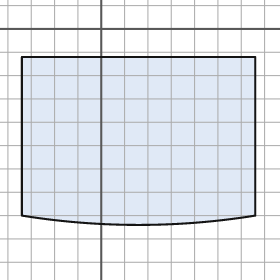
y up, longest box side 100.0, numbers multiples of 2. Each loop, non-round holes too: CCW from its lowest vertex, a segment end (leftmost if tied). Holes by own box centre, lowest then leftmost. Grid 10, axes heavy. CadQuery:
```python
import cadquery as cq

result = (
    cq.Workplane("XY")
    .moveTo(-34.0, -80.0)
    .threePointArc((16.0, -84.0), (66.0, -80.0))
    .lineTo(66.0, -12.0)
    .lineTo(-34.0, -12.0)
    .close()
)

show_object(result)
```